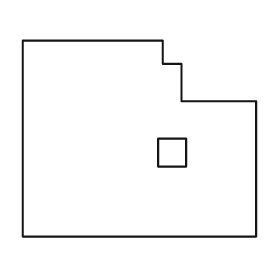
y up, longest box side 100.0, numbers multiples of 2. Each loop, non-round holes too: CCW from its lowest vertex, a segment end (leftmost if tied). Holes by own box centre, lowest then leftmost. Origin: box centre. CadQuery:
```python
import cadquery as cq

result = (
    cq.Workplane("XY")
    .moveTo(-50.0, -42.0)
    .lineTo(50.0, -42.0)
    .lineTo(50.0, 16.0)
    .lineTo(18.0, 16.0)
    .lineTo(18.0, 32.0)
    .lineTo(10.0, 32.0)
    .lineTo(10.0, 42.0)
    .lineTo(-50.0, 42.0)
    .close()
    .moveTo(8.0, -12.0)
    .lineTo(20.0, -12.0)
    .lineTo(20.0, 0.0)
    .lineTo(8.0, 0.0)
    .close()
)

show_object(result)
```